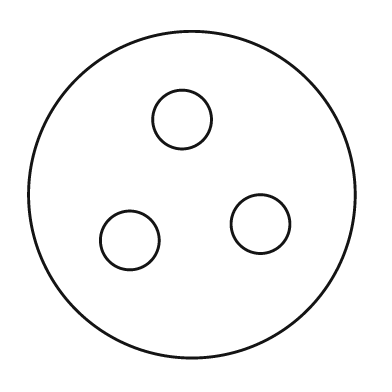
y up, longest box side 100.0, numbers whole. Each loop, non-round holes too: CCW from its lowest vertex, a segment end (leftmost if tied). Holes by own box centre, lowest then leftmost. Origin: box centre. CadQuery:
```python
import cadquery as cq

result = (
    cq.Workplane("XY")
    .moveTo(0.0, 0.0)
    .circle(50.0)
    .moveTo(-19.0, -14.0)
    .circle(9.0)
    .moveTo(21.0, -9.0)
    .circle(9.0)
    .moveTo(-3.0, 23.0)
    .circle(9.0)
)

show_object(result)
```